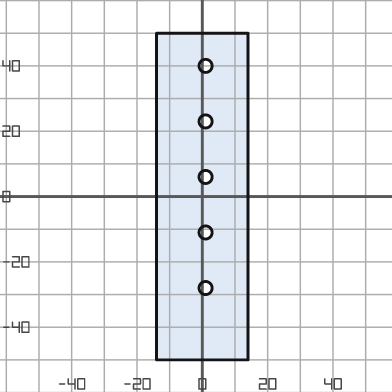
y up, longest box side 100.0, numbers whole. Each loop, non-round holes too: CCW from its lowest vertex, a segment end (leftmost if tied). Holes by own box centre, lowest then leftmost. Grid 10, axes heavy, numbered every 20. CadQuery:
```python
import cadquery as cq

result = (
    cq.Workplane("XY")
    .moveTo(-14.0, -50.0)
    .lineTo(14.0, -50.0)
    .lineTo(14.0, 50.0)
    .lineTo(-14.0, 50.0)
    .close()
    .moveTo(1.0, -28.0)
    .circle(2.0)
    .moveTo(1.0, -11.0)
    .circle(2.0)
    .moveTo(1.0, 6.0)
    .circle(2.0)
    .moveTo(1.0, 23.0)
    .circle(2.0)
    .moveTo(1.0, 40.0)
    .circle(2.0)
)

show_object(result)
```